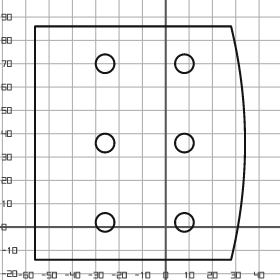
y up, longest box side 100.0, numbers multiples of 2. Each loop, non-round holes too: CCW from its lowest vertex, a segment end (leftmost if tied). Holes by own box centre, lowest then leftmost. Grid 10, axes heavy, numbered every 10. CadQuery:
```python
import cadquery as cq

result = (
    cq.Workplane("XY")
    .moveTo(-56.0, -14.0)
    .lineTo(28.0, -14.0)
    .threePointArc((34.0, 36.0), (28.0, 86.0))
    .lineTo(-56.0, 86.0)
    .close()
    .moveTo(-26.0, 2.0)
    .circle(4.0)
    .moveTo(8.0, 2.0)
    .circle(4.0)
    .moveTo(-26.0, 36.0)
    .circle(4.0)
    .moveTo(8.0, 36.0)
    .circle(4.0)
    .moveTo(-26.0, 70.0)
    .circle(4.0)
    .moveTo(8.0, 70.0)
    .circle(4.0)
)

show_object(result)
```